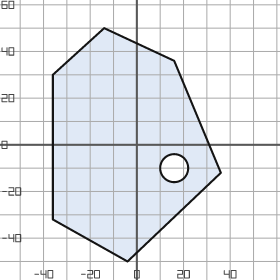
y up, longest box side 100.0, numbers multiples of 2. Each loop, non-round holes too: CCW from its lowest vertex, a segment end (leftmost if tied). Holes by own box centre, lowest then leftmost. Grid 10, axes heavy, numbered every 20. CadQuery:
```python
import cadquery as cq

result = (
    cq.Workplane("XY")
    .moveTo(-4.0, -50.0)
    .lineTo(36.0, -12.0)
    .lineTo(16.0, 36.0)
    .lineTo(-14.0, 50.0)
    .lineTo(-36.0, 30.0)
    .lineTo(-36.0, -32.0)
    .close()
    .moveTo(16.0, -10.0)
    .circle(6.0)
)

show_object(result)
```